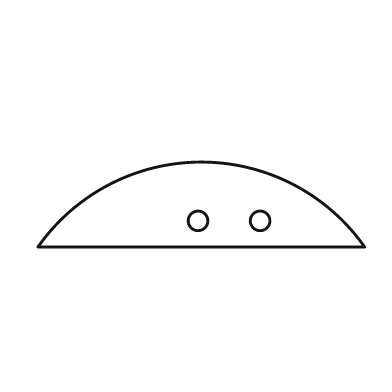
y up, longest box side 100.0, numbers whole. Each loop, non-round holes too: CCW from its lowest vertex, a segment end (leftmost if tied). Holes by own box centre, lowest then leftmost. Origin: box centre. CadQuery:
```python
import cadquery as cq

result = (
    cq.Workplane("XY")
    .moveTo(-50.0, -13.0)
    .lineTo(50.0, -13.0)
    .threePointArc((0.0, 13.0), (-50.0, -13.0))
    .close()
    .moveTo(-1.0, -5.0)
    .circle(3.0)
    .moveTo(18.0, -5.0)
    .circle(3.0)
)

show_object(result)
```